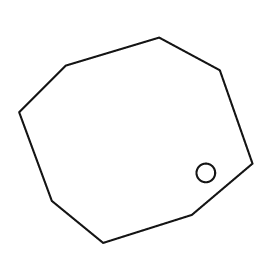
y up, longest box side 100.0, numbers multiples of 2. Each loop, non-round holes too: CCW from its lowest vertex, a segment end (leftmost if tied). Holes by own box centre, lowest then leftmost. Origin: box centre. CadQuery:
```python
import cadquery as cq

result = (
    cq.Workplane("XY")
    .moveTo(-14.0, -44.0)
    .lineTo(24.0, -32.0)
    .lineTo(50.0, -10.0)
    .lineTo(36.0, 30.0)
    .lineTo(10.0, 44.0)
    .lineTo(-30.0, 32.0)
    .lineTo(-50.0, 12.0)
    .lineTo(-36.0, -26.0)
    .close()
    .moveTo(30.0, -14.0)
    .circle(4.0)
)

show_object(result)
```